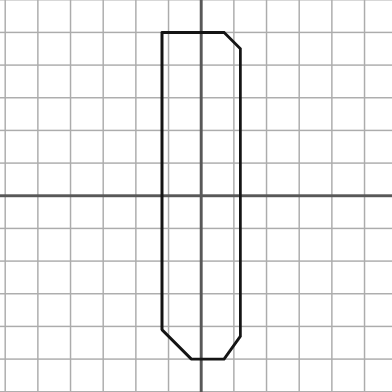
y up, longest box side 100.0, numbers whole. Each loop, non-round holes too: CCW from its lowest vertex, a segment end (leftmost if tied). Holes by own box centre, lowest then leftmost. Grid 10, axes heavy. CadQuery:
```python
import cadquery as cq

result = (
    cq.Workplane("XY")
    .moveTo(-3.0, -50.0)
    .lineTo(7.0, -50.0)
    .lineTo(12.0, -43.0)
    .lineTo(12.0, 45.0)
    .lineTo(7.0, 50.0)
    .lineTo(-12.0, 50.0)
    .lineTo(-12.0, -41.0)
    .close()
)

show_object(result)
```